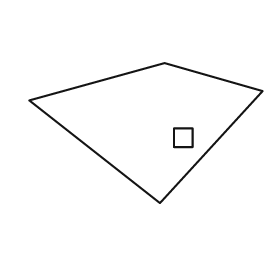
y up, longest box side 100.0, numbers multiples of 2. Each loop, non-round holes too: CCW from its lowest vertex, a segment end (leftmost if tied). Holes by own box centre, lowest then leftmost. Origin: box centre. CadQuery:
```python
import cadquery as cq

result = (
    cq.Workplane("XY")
    .moveTo(6.0, -30.0)
    .lineTo(50.0, 18.0)
    .lineTo(8.0, 30.0)
    .lineTo(-50.0, 14.0)
    .close()
    .moveTo(12.0, -6.0)
    .lineTo(20.0, -6.0)
    .lineTo(20.0, 2.0)
    .lineTo(12.0, 2.0)
    .close()
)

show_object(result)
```